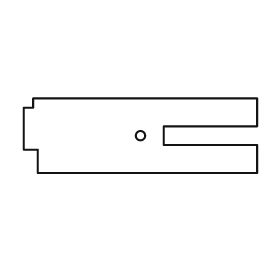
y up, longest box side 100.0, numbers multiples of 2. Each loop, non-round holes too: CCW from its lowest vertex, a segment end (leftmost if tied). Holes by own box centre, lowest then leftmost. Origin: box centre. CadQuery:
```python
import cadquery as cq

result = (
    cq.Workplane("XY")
    .moveTo(-44.0, -16.0)
    .lineTo(50.0, -16.0)
    .lineTo(50.0, -4.0)
    .lineTo(10.0, -4.0)
    .lineTo(10.0, 4.0)
    .lineTo(50.0, 4.0)
    .lineTo(50.0, 16.0)
    .lineTo(-46.0, 16.0)
    .lineTo(-46.0, 12.0)
    .lineTo(-50.0, 12.0)
    .lineTo(-50.0, -6.0)
    .lineTo(-44.0, -6.0)
    .close()
    .moveTo(0.0, 0.0)
    .circle(2.0)
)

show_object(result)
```